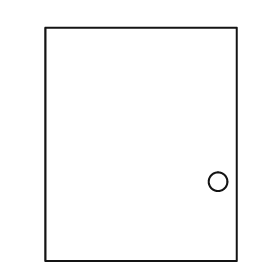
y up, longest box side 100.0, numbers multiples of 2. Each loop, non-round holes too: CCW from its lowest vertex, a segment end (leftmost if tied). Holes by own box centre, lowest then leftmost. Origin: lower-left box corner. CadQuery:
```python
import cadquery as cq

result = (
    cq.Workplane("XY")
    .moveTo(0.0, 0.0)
    .lineTo(82.0, 0.0)
    .lineTo(82.0, 100.0)
    .lineTo(0.0, 100.0)
    .close()
    .moveTo(74.0, 34.0)
    .circle(4.0)
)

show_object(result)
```